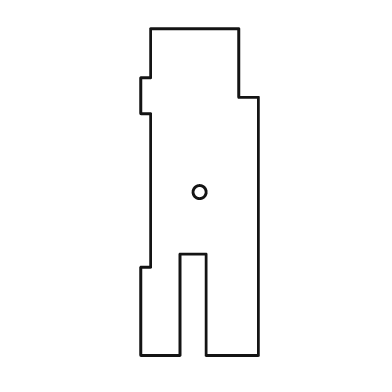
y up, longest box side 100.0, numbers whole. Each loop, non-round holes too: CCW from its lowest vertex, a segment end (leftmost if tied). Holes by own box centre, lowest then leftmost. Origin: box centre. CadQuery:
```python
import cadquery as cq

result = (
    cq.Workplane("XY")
    .moveTo(-18.0, -50.0)
    .lineTo(-6.0, -50.0)
    .lineTo(-6.0, -19.0)
    .lineTo(2.0, -19.0)
    .lineTo(2.0, -50.0)
    .lineTo(18.0, -50.0)
    .lineTo(18.0, 29.0)
    .lineTo(12.0, 29.0)
    .lineTo(12.0, 50.0)
    .lineTo(-15.0, 50.0)
    .lineTo(-15.0, 35.0)
    .lineTo(-18.0, 35.0)
    .lineTo(-18.0, 24.0)
    .lineTo(-15.0, 24.0)
    .lineTo(-15.0, -23.0)
    .lineTo(-18.0, -23.0)
    .close()
    .moveTo(0.0, 0.0)
    .circle(2.0)
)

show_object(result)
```